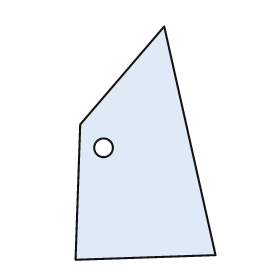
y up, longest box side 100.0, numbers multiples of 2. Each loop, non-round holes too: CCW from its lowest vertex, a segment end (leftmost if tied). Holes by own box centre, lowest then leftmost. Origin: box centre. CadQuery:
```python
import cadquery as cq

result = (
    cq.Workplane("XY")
    .moveTo(-30.0, -50.0)
    .lineTo(30.0, -48.0)
    .lineTo(8.0, 50.0)
    .lineTo(-28.0, 8.0)
    .close()
    .moveTo(-18.0, -2.0)
    .circle(4.0)
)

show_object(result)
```